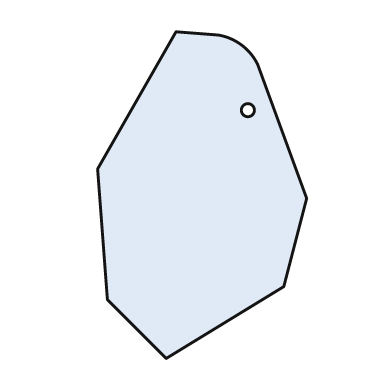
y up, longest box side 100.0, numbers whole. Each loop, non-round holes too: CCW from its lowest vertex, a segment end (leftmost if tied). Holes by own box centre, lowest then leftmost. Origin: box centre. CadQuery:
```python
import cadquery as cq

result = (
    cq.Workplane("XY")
    .moveTo(-11.0, -50.0)
    .lineTo(25.0, -28.0)
    .lineTo(32.0, -1.0)
    .lineTo(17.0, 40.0)
    .threePointArc((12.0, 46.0), (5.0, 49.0))
    .lineTo(-8.0, 50.0)
    .lineTo(-32.0, 8.0)
    .lineTo(-29.0, -32.0)
    .close()
    .moveTo(14.0, 26.0)
    .circle(2.0)
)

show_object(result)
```